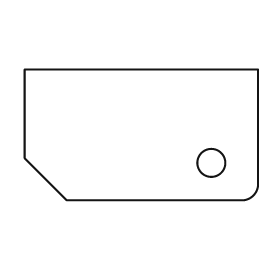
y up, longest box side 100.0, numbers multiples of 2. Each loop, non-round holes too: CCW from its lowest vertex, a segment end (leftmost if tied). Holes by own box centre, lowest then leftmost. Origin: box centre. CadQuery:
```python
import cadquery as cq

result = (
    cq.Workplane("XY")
    .moveTo(-32.0, -28.0)
    .lineTo(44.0, -28.0)
    .threePointArc((48.0, -26.0), (50.0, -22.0))
    .lineTo(50.0, 28.0)
    .lineTo(-50.0, 28.0)
    .lineTo(-50.0, -10.0)
    .close()
    .moveTo(30.0, -12.0)
    .circle(6.0)
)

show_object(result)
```